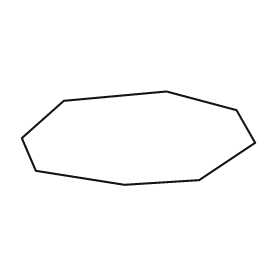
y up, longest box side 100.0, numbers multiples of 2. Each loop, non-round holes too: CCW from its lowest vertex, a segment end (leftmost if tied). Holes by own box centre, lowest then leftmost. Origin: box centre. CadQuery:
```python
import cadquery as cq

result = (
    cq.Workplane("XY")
    .moveTo(-6.0, -20.0)
    .lineTo(26.0, -18.0)
    .lineTo(50.0, -2.0)
    .lineTo(42.0, 12.0)
    .lineTo(12.0, 20.0)
    .lineTo(-32.0, 16.0)
    .lineTo(-50.0, 0.0)
    .lineTo(-44.0, -14.0)
    .close()
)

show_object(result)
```